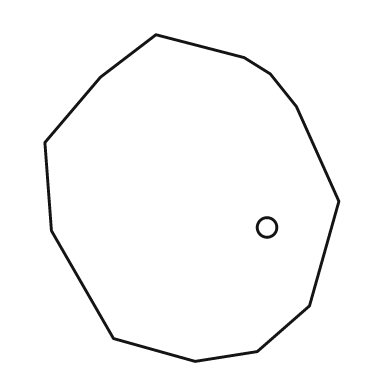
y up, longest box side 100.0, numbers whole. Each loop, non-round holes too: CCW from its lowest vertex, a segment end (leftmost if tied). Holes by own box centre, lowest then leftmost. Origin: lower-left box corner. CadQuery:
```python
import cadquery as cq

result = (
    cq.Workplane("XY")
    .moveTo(46.0, 0.0)
    .lineTo(65.0, 3.0)
    .lineTo(81.0, 17.0)
    .lineTo(90.0, 49.0)
    .lineTo(77.0, 78.0)
    .lineTo(69.0, 88.0)
    .lineTo(61.0, 93.0)
    .lineTo(34.0, 100.0)
    .lineTo(17.0, 87.0)
    .lineTo(0.0, 67.0)
    .lineTo(2.0, 40.0)
    .lineTo(21.0, 7.0)
    .close()
    .moveTo(68.0, 41.0)
    .circle(3.0)
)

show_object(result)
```